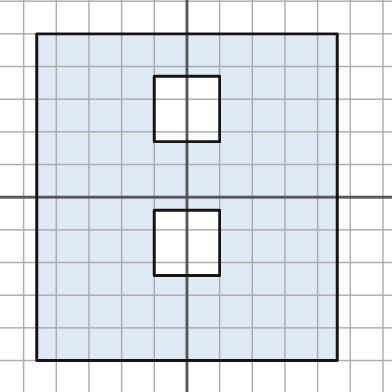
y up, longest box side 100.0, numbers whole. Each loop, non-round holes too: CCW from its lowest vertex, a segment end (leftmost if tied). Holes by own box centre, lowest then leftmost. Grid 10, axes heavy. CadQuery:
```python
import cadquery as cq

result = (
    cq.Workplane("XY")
    .moveTo(-46.0, -50.0)
    .lineTo(46.0, -50.0)
    .lineTo(46.0, 50.0)
    .lineTo(-46.0, 50.0)
    .close()
    .moveTo(-10.0, -24.0)
    .lineTo(10.0, -24.0)
    .lineTo(10.0, -4.0)
    .lineTo(-10.0, -4.0)
    .close()
    .moveTo(-10.0, 17.0)
    .lineTo(10.0, 17.0)
    .lineTo(10.0, 37.0)
    .lineTo(-10.0, 37.0)
    .close()
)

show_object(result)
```